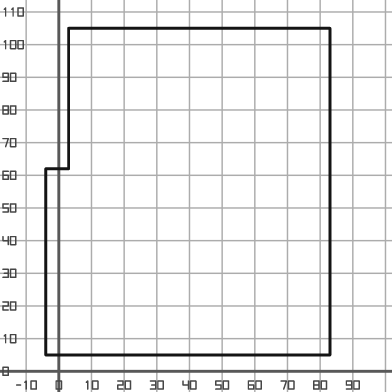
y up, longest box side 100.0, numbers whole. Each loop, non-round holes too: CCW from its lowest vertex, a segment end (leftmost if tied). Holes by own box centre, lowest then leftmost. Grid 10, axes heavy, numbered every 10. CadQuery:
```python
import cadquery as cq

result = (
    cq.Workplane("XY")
    .moveTo(-4.0, 5.0)
    .lineTo(83.0, 5.0)
    .lineTo(83.0, 105.0)
    .lineTo(3.0, 105.0)
    .lineTo(3.0, 62.0)
    .lineTo(-4.0, 62.0)
    .close()
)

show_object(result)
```